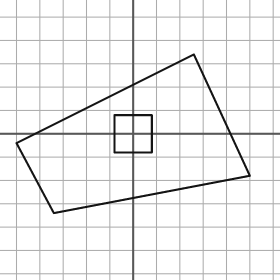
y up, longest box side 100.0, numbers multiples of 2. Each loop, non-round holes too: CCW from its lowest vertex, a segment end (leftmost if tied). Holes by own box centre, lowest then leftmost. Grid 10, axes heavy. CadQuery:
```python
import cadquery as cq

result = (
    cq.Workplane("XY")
    .moveTo(-34.0, -34.0)
    .lineTo(50.0, -18.0)
    .lineTo(26.0, 34.0)
    .lineTo(-50.0, -4.0)
    .close()
    .moveTo(-8.0, -8.0)
    .lineTo(8.0, -8.0)
    .lineTo(8.0, 8.0)
    .lineTo(-8.0, 8.0)
    .close()
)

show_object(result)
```